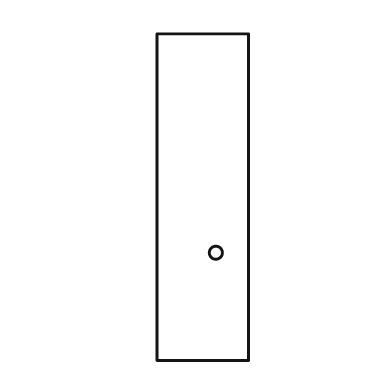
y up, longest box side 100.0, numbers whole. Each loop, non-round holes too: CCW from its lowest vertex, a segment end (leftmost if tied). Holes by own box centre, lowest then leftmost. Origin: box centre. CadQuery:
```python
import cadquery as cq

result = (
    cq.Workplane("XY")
    .moveTo(-14.0, -50.0)
    .lineTo(14.0, -50.0)
    .lineTo(14.0, 50.0)
    .lineTo(-14.0, 50.0)
    .close()
    .moveTo(4.0, -17.0)
    .circle(2.0)
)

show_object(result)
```